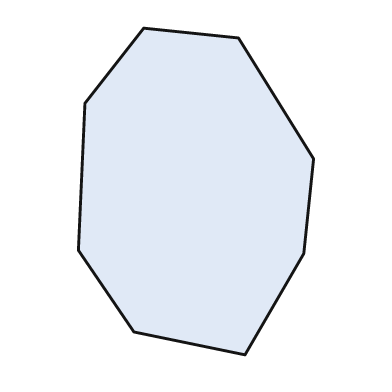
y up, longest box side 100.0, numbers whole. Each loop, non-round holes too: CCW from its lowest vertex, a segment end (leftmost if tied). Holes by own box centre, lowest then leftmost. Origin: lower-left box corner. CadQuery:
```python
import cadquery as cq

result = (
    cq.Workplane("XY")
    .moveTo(51.0, 0.0)
    .lineTo(69.0, 31.0)
    .lineTo(72.0, 60.0)
    .lineTo(49.0, 97.0)
    .lineTo(20.0, 100.0)
    .lineTo(2.0, 77.0)
    .lineTo(0.0, 32.0)
    .lineTo(17.0, 7.0)
    .close()
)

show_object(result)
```